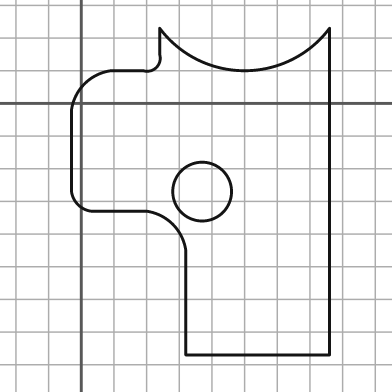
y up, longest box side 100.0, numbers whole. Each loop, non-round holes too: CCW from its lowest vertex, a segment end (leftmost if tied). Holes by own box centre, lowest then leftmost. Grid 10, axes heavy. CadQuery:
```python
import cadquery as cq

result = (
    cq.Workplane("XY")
    .moveTo(32.0, -77.0)
    .lineTo(76.0, -77.0)
    .lineTo(76.0, 23.0)
    .threePointArc((50.0, 10.0), (24.0, 23.0))
    .lineTo(24.0, 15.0)
    .threePointArc((23.0, 11.0), (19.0, 10.0))
    .lineTo(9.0, 10.0)
    .threePointArc((1.0, 6.0), (-3.0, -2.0))
    .lineTo(-3.0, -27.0)
    .threePointArc((-1.0, -31.0), (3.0, -33.0))
    .lineTo(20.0, -33.0)
    .threePointArc((28.0, -37.0), (32.0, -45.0))
    .close()
    .moveTo(37.0, -27.0)
    .circle(9.0)
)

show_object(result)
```